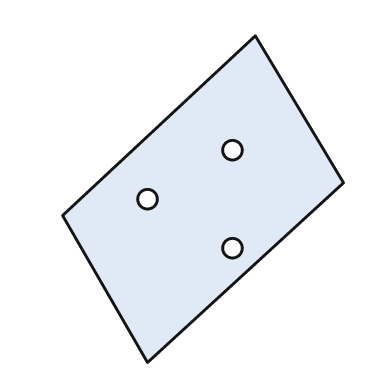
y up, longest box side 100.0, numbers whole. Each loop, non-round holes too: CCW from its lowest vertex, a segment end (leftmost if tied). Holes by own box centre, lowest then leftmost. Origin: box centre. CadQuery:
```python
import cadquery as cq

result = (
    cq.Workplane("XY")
    .moveTo(-17.0, -50.0)
    .lineTo(43.0, 5.0)
    .lineTo(16.0, 50.0)
    .lineTo(-43.0, -5.0)
    .close()
    .moveTo(9.0, -15.0)
    .circle(3.0)
    .moveTo(-17.0, 0.0)
    .circle(3.0)
    .moveTo(9.0, 15.0)
    .circle(3.0)
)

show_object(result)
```